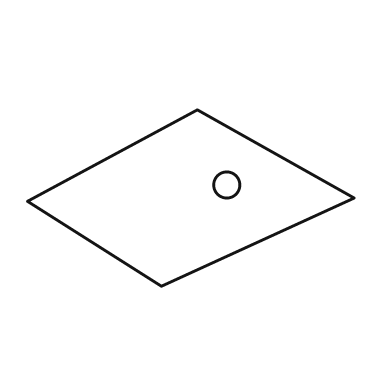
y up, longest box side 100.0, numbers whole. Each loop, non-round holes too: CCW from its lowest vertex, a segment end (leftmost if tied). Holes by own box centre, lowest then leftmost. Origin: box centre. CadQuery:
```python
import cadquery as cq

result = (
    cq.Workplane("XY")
    .moveTo(-9.0, -27.0)
    .lineTo(50.0, 0.0)
    .lineTo(2.0, 27.0)
    .lineTo(-50.0, -1.0)
    .close()
    .moveTo(11.0, 4.0)
    .circle(4.0)
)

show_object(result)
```